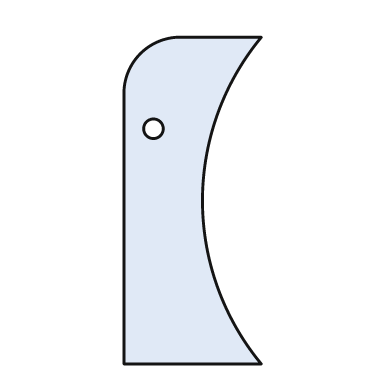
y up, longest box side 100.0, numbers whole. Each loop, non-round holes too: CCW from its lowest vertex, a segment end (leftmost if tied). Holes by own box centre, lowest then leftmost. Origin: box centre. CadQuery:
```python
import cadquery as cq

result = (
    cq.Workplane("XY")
    .moveTo(-21.0, -50.0)
    .lineTo(21.0, -50.0)
    .threePointArc((3.0, 0.0), (21.0, 50.0))
    .lineTo(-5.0, 50.0)
    .threePointArc((-16.0, 45.0), (-21.0, 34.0))
    .close()
    .moveTo(-12.0, 22.0)
    .circle(3.0)
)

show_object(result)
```